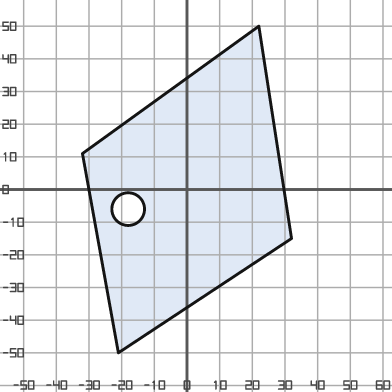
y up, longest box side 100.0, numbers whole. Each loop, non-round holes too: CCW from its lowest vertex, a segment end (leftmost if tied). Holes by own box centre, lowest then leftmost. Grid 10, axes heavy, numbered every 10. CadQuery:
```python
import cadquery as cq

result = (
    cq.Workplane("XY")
    .moveTo(-21.0, -50.0)
    .lineTo(32.0, -15.0)
    .lineTo(22.0, 50.0)
    .lineTo(-32.0, 11.0)
    .close()
    .moveTo(-18.0, -6.0)
    .circle(5.0)
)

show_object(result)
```